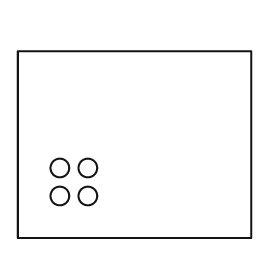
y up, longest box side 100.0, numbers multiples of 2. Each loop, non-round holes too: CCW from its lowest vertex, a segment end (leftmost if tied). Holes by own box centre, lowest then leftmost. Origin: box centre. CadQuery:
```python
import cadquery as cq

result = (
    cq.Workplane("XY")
    .moveTo(-50.0, -40.0)
    .lineTo(50.0, -40.0)
    .lineTo(50.0, 40.0)
    .lineTo(-50.0, 40.0)
    .close()
    .moveTo(-32.0, -22.0)
    .circle(4.0)
    .moveTo(-20.0, -22.0)
    .circle(4.0)
    .moveTo(-32.0, -10.0)
    .circle(4.0)
    .moveTo(-20.0, -10.0)
    .circle(4.0)
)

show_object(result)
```